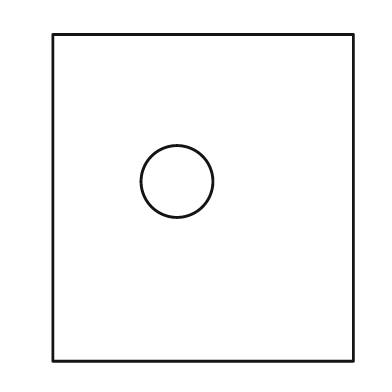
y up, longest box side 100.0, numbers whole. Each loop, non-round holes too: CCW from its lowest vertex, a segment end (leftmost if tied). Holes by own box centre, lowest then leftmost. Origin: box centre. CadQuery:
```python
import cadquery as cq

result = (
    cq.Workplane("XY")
    .moveTo(-46.0, -50.0)
    .lineTo(46.0, -50.0)
    .lineTo(46.0, 50.0)
    .lineTo(-46.0, 50.0)
    .close()
    .moveTo(-8.0, 5.0)
    .circle(11.0)
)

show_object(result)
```